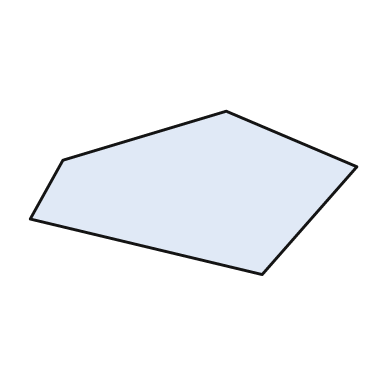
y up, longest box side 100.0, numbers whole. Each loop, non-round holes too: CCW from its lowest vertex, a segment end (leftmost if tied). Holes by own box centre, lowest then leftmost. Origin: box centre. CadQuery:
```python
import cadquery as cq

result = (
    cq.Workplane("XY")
    .moveTo(21.0, -25.0)
    .lineTo(50.0, 8.0)
    .lineTo(10.0, 25.0)
    .lineTo(-40.0, 10.0)
    .lineTo(-50.0, -8.0)
    .close()
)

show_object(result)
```